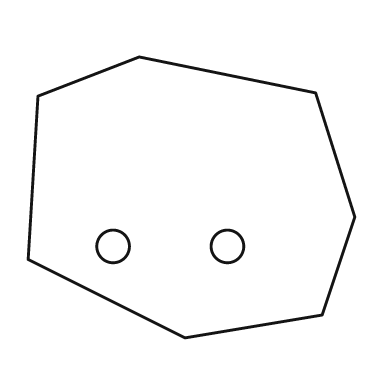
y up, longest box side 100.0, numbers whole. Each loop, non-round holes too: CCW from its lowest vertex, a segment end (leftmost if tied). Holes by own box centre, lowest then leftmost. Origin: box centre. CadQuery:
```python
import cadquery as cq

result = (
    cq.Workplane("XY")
    .moveTo(-2.0, -43.0)
    .lineTo(40.0, -36.0)
    .lineTo(50.0, -6.0)
    .lineTo(38.0, 32.0)
    .lineTo(-16.0, 43.0)
    .lineTo(-47.0, 31.0)
    .lineTo(-50.0, -19.0)
    .close()
    .moveTo(-24.0, -15.0)
    .circle(5.0)
    .moveTo(11.0, -15.0)
    .circle(5.0)
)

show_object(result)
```